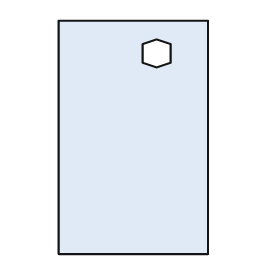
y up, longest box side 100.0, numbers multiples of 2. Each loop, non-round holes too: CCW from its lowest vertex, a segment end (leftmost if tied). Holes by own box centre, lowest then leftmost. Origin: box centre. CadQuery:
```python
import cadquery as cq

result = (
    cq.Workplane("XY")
    .moveTo(-32.0, -50.0)
    .lineTo(32.0, -50.0)
    .lineTo(32.0, 50.0)
    .lineTo(-32.0, 50.0)
    .close()
    .moveTo(10.0, 30.0)
    .lineTo(16.0, 32.0)
    .lineTo(16.0, 40.0)
    .lineTo(10.0, 42.0)
    .lineTo(4.0, 40.0)
    .lineTo(4.0, 32.0)
    .close()
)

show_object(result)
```